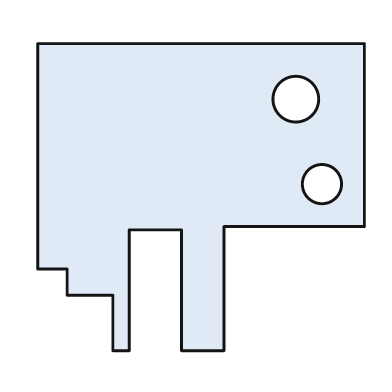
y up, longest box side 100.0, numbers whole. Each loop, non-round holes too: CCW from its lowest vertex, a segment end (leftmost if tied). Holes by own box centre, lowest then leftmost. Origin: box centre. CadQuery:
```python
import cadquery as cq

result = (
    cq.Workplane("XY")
    .moveTo(-27.0, -47.0)
    .lineTo(-22.0, -47.0)
    .lineTo(-22.0, -10.0)
    .lineTo(-6.0, -10.0)
    .lineTo(-6.0, -47.0)
    .lineTo(7.0, -47.0)
    .lineTo(7.0, -9.0)
    .lineTo(50.0, -9.0)
    .lineTo(50.0, 47.0)
    .lineTo(-50.0, 47.0)
    .lineTo(-50.0, -22.0)
    .lineTo(-41.0, -22.0)
    .lineTo(-41.0, -30.0)
    .lineTo(-27.0, -30.0)
    .close()
    .moveTo(37.0, 4.0)
    .circle(6.0)
    .moveTo(29.0, 30.0)
    .circle(7.0)
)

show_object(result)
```